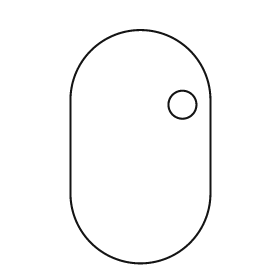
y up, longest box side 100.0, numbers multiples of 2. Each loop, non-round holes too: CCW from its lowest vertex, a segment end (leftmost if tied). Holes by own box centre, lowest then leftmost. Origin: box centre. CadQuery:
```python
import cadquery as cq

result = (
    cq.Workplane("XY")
    .moveTo(-30.0, -20.0)
    .threePointArc((0.0, -50.0), (30.0, -20.0))
    .lineTo(30.0, 20.0)
    .threePointArc((0.0, 50.0), (-30.0, 20.0))
    .close()
    .moveTo(18.0, 18.0)
    .circle(6.0)
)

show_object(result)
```